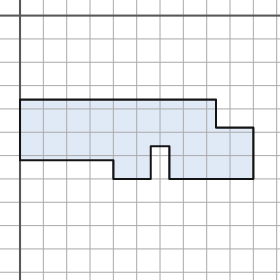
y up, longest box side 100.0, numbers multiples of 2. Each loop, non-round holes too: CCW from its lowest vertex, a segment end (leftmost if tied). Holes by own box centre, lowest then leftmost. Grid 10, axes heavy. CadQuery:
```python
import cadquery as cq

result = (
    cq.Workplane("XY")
    .moveTo(40.0, -70.0)
    .lineTo(56.0, -70.0)
    .lineTo(56.0, -56.0)
    .lineTo(64.0, -56.0)
    .lineTo(64.0, -70.0)
    .lineTo(100.0, -70.0)
    .lineTo(100.0, -48.0)
    .lineTo(84.0, -48.0)
    .lineTo(84.0, -36.0)
    .lineTo(0.0, -36.0)
    .lineTo(0.0, -62.0)
    .lineTo(40.0, -62.0)
    .close()
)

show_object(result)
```